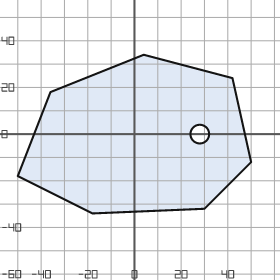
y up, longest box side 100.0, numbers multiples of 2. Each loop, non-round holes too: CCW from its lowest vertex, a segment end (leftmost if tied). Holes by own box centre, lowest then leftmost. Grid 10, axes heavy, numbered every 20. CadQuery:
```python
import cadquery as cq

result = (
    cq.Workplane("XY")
    .moveTo(-18.0, -34.0)
    .lineTo(30.0, -32.0)
    .lineTo(50.0, -12.0)
    .lineTo(42.0, 24.0)
    .lineTo(4.0, 34.0)
    .lineTo(-36.0, 18.0)
    .lineTo(-50.0, -18.0)
    .close()
    .moveTo(28.0, 0.0)
    .circle(4.0)
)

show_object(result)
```